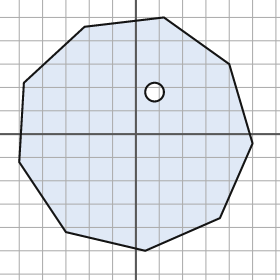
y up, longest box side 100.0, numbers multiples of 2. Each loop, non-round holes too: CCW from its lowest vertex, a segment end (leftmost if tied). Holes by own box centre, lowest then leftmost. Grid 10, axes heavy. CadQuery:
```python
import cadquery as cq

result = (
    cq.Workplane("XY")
    .moveTo(4.0, -50.0)
    .lineTo(36.0, -36.0)
    .lineTo(50.0, -4.0)
    .lineTo(40.0, 30.0)
    .lineTo(12.0, 50.0)
    .lineTo(-22.0, 46.0)
    .lineTo(-48.0, 22.0)
    .lineTo(-50.0, -12.0)
    .lineTo(-30.0, -42.0)
    .close()
    .moveTo(8.0, 18.0)
    .circle(4.0)
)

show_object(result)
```